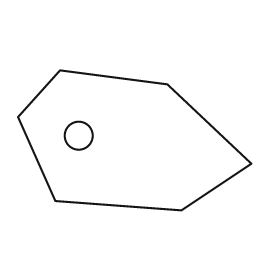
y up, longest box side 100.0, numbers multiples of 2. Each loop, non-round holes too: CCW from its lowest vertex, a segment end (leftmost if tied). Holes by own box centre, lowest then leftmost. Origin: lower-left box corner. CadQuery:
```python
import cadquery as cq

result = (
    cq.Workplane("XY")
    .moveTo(70.0, 0.0)
    .lineTo(100.0, 20.0)
    .lineTo(64.0, 54.0)
    .lineTo(18.0, 60.0)
    .lineTo(0.0, 40.0)
    .lineTo(16.0, 4.0)
    .close()
    .moveTo(26.0, 32.0)
    .circle(6.0)
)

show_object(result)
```